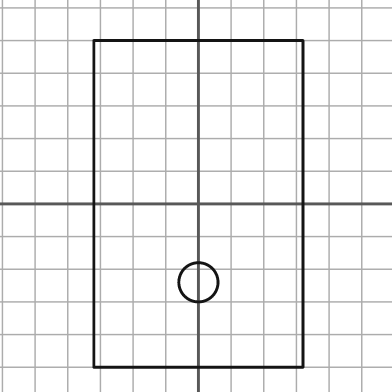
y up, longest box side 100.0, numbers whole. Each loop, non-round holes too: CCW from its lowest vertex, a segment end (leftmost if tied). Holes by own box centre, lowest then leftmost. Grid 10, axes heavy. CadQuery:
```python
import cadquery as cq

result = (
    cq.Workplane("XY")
    .moveTo(-32.0, -50.0)
    .lineTo(32.0, -50.0)
    .lineTo(32.0, 50.0)
    .lineTo(-32.0, 50.0)
    .close()
    .moveTo(0.0, -24.0)
    .circle(6.0)
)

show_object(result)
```